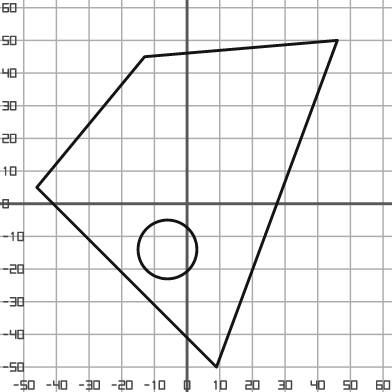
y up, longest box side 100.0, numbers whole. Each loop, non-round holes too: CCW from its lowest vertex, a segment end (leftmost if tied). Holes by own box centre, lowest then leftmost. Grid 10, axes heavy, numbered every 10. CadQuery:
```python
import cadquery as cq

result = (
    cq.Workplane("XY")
    .moveTo(9.0, -50.0)
    .lineTo(46.0, 50.0)
    .lineTo(-13.0, 45.0)
    .lineTo(-46.0, 5.0)
    .close()
    .moveTo(-6.0, -14.0)
    .circle(9.0)
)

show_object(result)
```